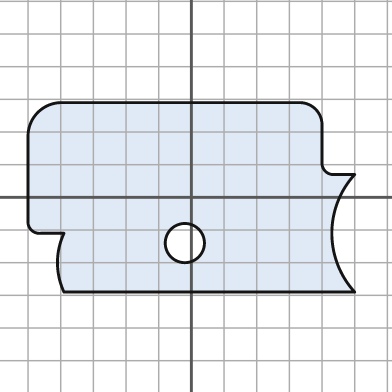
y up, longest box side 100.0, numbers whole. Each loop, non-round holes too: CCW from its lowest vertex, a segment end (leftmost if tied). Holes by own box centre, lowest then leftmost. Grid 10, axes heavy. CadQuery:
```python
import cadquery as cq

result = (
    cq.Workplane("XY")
    .moveTo(-39.0, -29.0)
    .lineTo(50.0, -29.0)
    .threePointArc((43.0, -11.0), (50.0, 7.0))
    .lineTo(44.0, 7.0)
    .threePointArc((41.0, 8.0), (40.0, 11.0))
    .lineTo(40.0, 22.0)
    .threePointArc((38.0, 27.0), (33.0, 29.0))
    .lineTo(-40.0, 29.0)
    .threePointArc((-47.0, 26.0), (-50.0, 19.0))
    .lineTo(-50.0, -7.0)
    .threePointArc((-49.0, -10.0), (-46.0, -11.0))
    .lineTo(-39.0, -11.0)
    .threePointArc((-41.0, -20.0), (-39.0, -29.0))
    .close()
    .moveTo(-2.0, -14.0)
    .circle(6.0)
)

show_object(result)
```